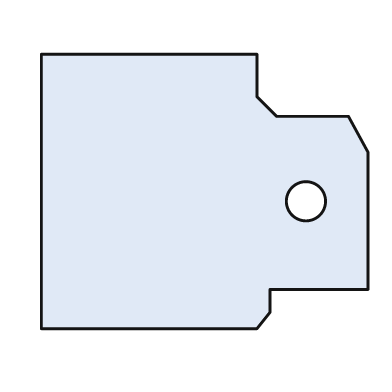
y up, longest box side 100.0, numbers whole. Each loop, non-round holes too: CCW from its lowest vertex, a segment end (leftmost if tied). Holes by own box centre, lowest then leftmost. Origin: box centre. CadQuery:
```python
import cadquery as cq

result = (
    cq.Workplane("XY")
    .moveTo(-50.0, -42.0)
    .lineTo(16.0, -42.0)
    .lineTo(20.0, -37.0)
    .lineTo(20.0, -30.0)
    .lineTo(50.0, -30.0)
    .lineTo(50.0, 12.0)
    .lineTo(44.0, 23.0)
    .lineTo(22.0, 23.0)
    .lineTo(16.0, 29.0)
    .lineTo(16.0, 42.0)
    .lineTo(-50.0, 42.0)
    .close()
    .moveTo(31.0, -3.0)
    .circle(6.0)
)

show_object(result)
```